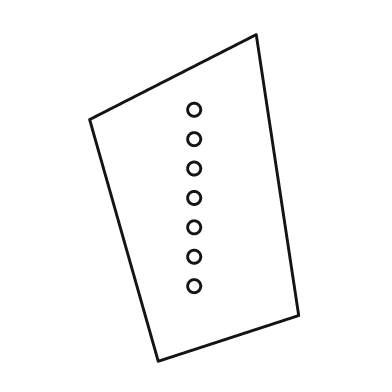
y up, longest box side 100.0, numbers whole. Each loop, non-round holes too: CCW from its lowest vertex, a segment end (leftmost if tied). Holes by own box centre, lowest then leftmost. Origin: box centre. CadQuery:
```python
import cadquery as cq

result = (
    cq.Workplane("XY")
    .moveTo(-11.0, -50.0)
    .lineTo(32.0, -36.0)
    .lineTo(19.0, 50.0)
    .lineTo(-32.0, 24.0)
    .close()
    .moveTo(0.0, -27.0)
    .circle(2.0)
    .moveTo(0.0, -18.0)
    .circle(2.0)
    .moveTo(0.0, -9.0)
    .circle(2.0)
    .moveTo(0.0, 0.0)
    .circle(2.0)
    .moveTo(0.0, 9.0)
    .circle(2.0)
    .moveTo(0.0, 18.0)
    .circle(2.0)
    .moveTo(0.0, 27.0)
    .circle(2.0)
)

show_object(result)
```